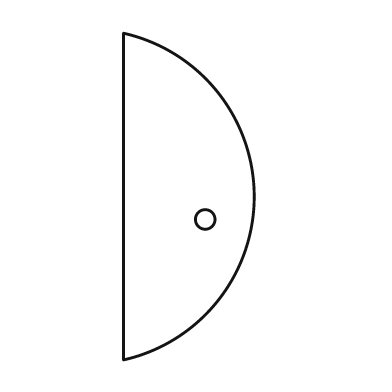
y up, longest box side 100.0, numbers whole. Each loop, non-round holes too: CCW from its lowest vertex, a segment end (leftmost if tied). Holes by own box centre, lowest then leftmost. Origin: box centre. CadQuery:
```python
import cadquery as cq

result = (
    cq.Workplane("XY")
    .moveTo(-20.0, -50.0)
    .threePointArc((20.0, 0.0), (-20.0, 50.0))
    .close()
    .moveTo(5.0, -7.0)
    .circle(3.0)
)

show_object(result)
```